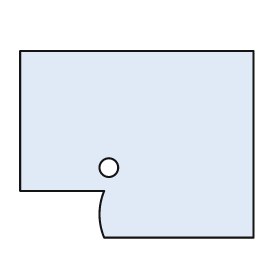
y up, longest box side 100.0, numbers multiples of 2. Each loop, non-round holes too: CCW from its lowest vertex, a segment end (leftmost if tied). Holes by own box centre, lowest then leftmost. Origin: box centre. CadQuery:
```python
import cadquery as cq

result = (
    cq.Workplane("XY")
    .moveTo(-14.0, -40.0)
    .lineTo(50.0, -40.0)
    .lineTo(50.0, 40.0)
    .lineTo(-50.0, 40.0)
    .lineTo(-50.0, -20.0)
    .lineTo(-14.0, -20.0)
    .threePointArc((-16.0, -30.0), (-14.0, -40.0))
    .close()
    .moveTo(-12.0, -10.0)
    .circle(4.0)
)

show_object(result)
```